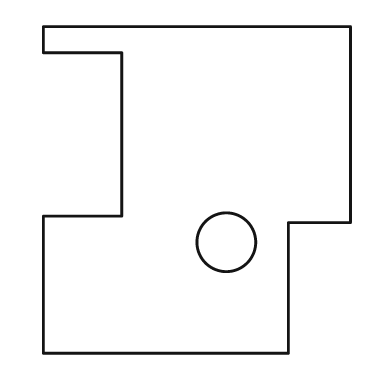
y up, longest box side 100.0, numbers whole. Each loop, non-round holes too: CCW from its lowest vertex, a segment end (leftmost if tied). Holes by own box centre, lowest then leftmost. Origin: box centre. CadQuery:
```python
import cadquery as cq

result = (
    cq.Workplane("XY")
    .moveTo(-47.0, -50.0)
    .lineTo(28.0, -50.0)
    .lineTo(28.0, -10.0)
    .lineTo(47.0, -10.0)
    .lineTo(47.0, 50.0)
    .lineTo(-47.0, 50.0)
    .lineTo(-47.0, 42.0)
    .lineTo(-23.0, 42.0)
    .lineTo(-23.0, -8.0)
    .lineTo(-47.0, -8.0)
    .close()
    .moveTo(9.0, -16.0)
    .circle(9.0)
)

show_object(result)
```